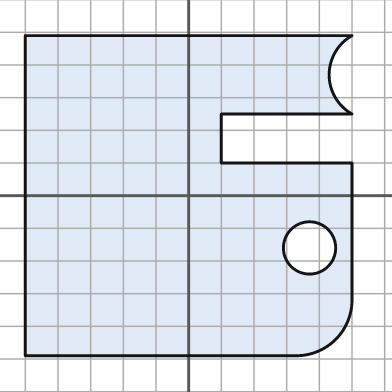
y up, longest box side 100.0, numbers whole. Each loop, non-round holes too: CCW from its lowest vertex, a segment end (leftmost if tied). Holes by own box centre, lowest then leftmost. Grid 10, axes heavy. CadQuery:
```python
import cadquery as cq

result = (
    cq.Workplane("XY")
    .moveTo(-50.0, -49.0)
    .lineTo(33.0, -49.0)
    .threePointArc((45.0, -44.0), (50.0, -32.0))
    .lineTo(50.0, 10.0)
    .lineTo(10.0, 10.0)
    .lineTo(10.0, 25.0)
    .lineTo(50.0, 25.0)
    .threePointArc((43.0, 37.0), (50.0, 49.0))
    .lineTo(-50.0, 49.0)
    .close()
    .moveTo(37.0, -16.0)
    .circle(8.0)
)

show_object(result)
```